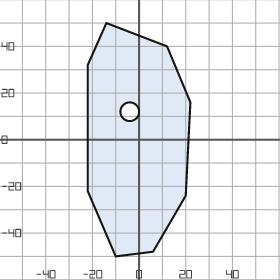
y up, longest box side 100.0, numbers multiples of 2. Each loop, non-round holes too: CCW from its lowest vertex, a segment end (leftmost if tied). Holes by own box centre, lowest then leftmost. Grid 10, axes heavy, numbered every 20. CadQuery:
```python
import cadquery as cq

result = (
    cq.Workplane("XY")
    .moveTo(-10.0, -50.0)
    .lineTo(6.0, -48.0)
    .lineTo(20.0, -24.0)
    .lineTo(22.0, 16.0)
    .lineTo(12.0, 40.0)
    .lineTo(-14.0, 50.0)
    .lineTo(-22.0, 32.0)
    .lineTo(-22.0, -22.0)
    .close()
    .moveTo(-4.0, 12.0)
    .circle(4.0)
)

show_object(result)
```